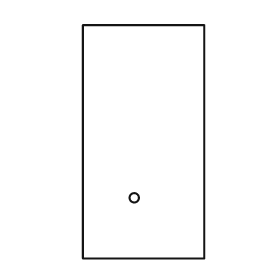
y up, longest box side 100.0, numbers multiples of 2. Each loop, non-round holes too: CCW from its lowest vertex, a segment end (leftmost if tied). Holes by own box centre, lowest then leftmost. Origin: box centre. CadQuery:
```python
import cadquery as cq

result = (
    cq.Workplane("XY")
    .moveTo(-26.0, -50.0)
    .lineTo(26.0, -50.0)
    .lineTo(26.0, 50.0)
    .lineTo(-26.0, 50.0)
    .close()
    .moveTo(-4.0, -24.0)
    .circle(2.0)
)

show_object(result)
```